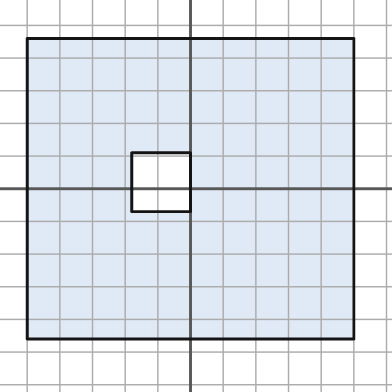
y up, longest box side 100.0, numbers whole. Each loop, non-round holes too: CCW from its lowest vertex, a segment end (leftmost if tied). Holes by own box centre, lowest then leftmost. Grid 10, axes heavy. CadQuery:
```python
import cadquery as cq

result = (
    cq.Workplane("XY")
    .moveTo(-50.0, -46.0)
    .lineTo(50.0, -46.0)
    .lineTo(50.0, 46.0)
    .lineTo(-50.0, 46.0)
    .close()
    .moveTo(-18.0, -7.0)
    .lineTo(0.0, -7.0)
    .lineTo(0.0, 11.0)
    .lineTo(-18.0, 11.0)
    .close()
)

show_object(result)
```